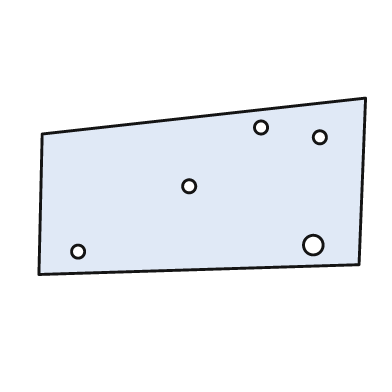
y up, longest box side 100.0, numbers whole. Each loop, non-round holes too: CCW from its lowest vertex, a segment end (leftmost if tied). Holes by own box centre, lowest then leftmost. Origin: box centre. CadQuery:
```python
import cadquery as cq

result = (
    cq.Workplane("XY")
    .moveTo(-50.0, -27.0)
    .lineTo(48.0, -24.0)
    .lineTo(50.0, 27.0)
    .lineTo(-49.0, 16.0)
    .close()
    .moveTo(-38.0, -20.0)
    .circle(2.0)
    .moveTo(34.0, -18.0)
    .circle(3.0)
    .moveTo(-4.0, 0.0)
    .circle(2.0)
    .moveTo(36.0, 15.0)
    .circle(2.0)
    .moveTo(18.0, 18.0)
    .circle(2.0)
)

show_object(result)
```